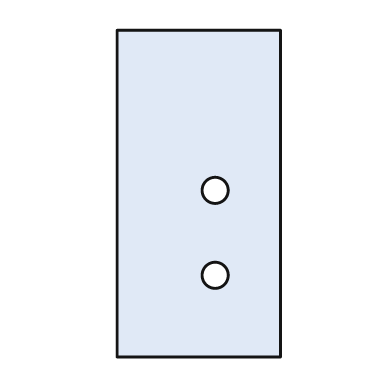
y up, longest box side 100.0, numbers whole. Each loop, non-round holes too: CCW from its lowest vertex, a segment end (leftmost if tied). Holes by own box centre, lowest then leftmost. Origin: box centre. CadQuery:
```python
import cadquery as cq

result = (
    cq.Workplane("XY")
    .moveTo(-25.0, -50.0)
    .lineTo(25.0, -50.0)
    .lineTo(25.0, 50.0)
    .lineTo(-25.0, 50.0)
    .close()
    .moveTo(5.0, -25.0)
    .circle(4.0)
    .moveTo(5.0, 1.0)
    .circle(4.0)
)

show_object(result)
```